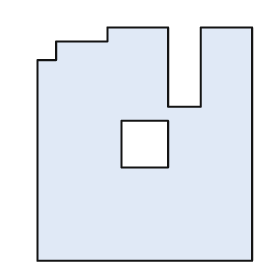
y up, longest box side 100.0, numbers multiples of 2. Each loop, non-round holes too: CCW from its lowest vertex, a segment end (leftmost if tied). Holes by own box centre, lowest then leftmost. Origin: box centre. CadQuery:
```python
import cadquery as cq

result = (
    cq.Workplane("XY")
    .moveTo(-46.0, -50.0)
    .lineTo(46.0, -50.0)
    .lineTo(46.0, 50.0)
    .lineTo(24.0, 50.0)
    .lineTo(24.0, 16.0)
    .lineTo(10.0, 16.0)
    .lineTo(10.0, 50.0)
    .lineTo(-16.0, 50.0)
    .lineTo(-16.0, 44.0)
    .lineTo(-38.0, 44.0)
    .lineTo(-38.0, 36.0)
    .lineTo(-46.0, 36.0)
    .close()
    .moveTo(-10.0, -10.0)
    .lineTo(10.0, -10.0)
    .lineTo(10.0, 10.0)
    .lineTo(-10.0, 10.0)
    .close()
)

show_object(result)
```